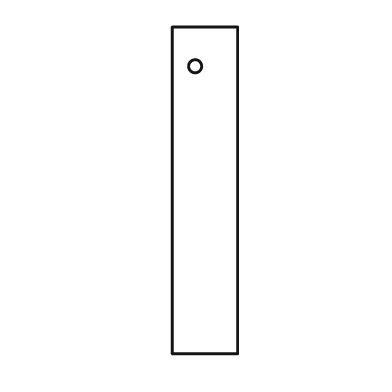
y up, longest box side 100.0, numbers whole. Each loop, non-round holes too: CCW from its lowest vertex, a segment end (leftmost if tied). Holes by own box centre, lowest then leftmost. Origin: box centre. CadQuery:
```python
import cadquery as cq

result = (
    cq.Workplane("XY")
    .moveTo(-10.0, -50.0)
    .lineTo(10.0, -50.0)
    .lineTo(10.0, 50.0)
    .lineTo(-10.0, 50.0)
    .close()
    .moveTo(-3.0, 38.0)
    .circle(2.0)
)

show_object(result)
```